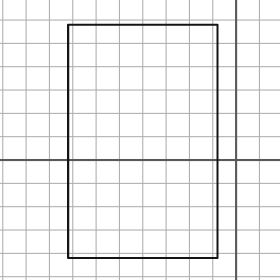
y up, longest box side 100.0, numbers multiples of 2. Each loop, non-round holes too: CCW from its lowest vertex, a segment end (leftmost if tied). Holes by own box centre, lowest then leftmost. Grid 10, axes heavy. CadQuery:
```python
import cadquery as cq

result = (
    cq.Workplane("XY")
    .moveTo(-72.0, -42.0)
    .lineTo(-8.0, -42.0)
    .lineTo(-8.0, 58.0)
    .lineTo(-72.0, 58.0)
    .close()
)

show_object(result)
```